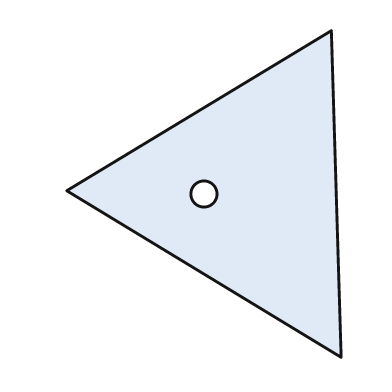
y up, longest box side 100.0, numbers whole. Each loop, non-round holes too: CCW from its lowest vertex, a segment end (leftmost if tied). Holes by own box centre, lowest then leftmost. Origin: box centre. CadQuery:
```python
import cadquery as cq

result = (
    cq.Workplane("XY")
    .moveTo(42.0, -50.0)
    .lineTo(39.0, 50.0)
    .lineTo(-42.0, 1.0)
    .close()
    .moveTo(0.0, 0.0)
    .circle(4.0)
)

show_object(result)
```